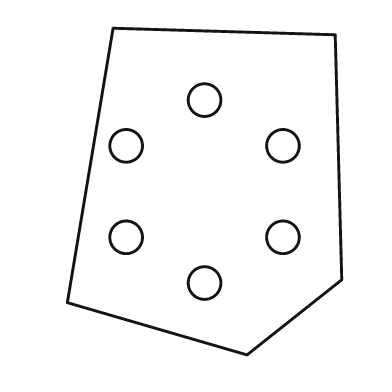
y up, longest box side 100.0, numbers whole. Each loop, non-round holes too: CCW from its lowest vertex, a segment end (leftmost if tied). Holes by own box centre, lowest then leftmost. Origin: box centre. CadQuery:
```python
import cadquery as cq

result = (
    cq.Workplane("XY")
    .moveTo(13.0, -50.0)
    .lineTo(42.0, -27.0)
    .lineTo(40.0, 48.0)
    .lineTo(-28.0, 50.0)
    .lineTo(-42.0, -34.0)
    .close()
    .moveTo(0.0, -28.0)
    .circle(5.0)
    .moveTo(-24.0, -14.0)
    .circle(5.0)
    .moveTo(24.0, -14.0)
    .circle(5.0)
    .moveTo(-24.0, 14.0)
    .circle(5.0)
    .moveTo(24.0, 14.0)
    .circle(5.0)
    .moveTo(0.0, 28.0)
    .circle(5.0)
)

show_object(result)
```